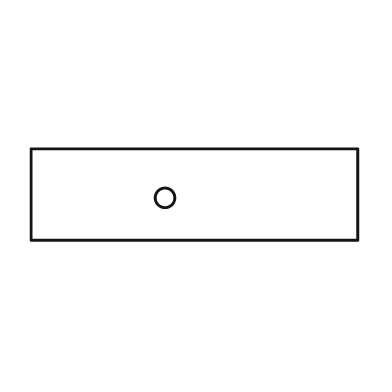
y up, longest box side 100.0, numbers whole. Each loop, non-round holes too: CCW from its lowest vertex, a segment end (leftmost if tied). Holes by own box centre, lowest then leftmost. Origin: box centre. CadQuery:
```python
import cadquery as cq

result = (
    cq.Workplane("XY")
    .moveTo(-50.0, -14.0)
    .lineTo(50.0, -14.0)
    .lineTo(50.0, 14.0)
    .lineTo(-50.0, 14.0)
    .close()
    .moveTo(-9.0, -1.0)
    .circle(3.0)
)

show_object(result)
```